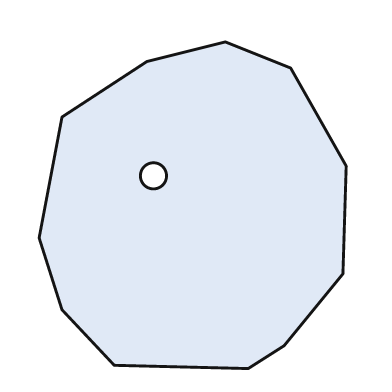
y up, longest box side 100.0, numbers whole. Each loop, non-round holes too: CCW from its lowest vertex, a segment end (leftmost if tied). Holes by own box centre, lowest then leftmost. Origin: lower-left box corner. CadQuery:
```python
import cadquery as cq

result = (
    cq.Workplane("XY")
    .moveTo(64.0, 0.0)
    .lineTo(75.0, 7.0)
    .lineTo(93.0, 29.0)
    .lineTo(94.0, 62.0)
    .lineTo(77.0, 92.0)
    .lineTo(57.0, 100.0)
    .lineTo(33.0, 94.0)
    .lineTo(7.0, 77.0)
    .lineTo(0.0, 40.0)
    .lineTo(7.0, 18.0)
    .lineTo(23.0, 1.0)
    .close()
    .moveTo(35.0, 59.0)
    .circle(4.0)
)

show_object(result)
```